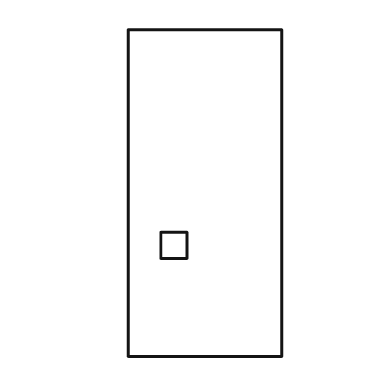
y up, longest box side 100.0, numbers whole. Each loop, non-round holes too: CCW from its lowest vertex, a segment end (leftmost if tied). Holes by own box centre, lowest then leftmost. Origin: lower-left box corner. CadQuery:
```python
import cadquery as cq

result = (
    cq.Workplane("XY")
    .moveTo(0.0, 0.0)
    .lineTo(47.0, 0.0)
    .lineTo(47.0, 100.0)
    .lineTo(0.0, 100.0)
    .close()
    .moveTo(10.0, 30.0)
    .lineTo(18.0, 30.0)
    .lineTo(18.0, 38.0)
    .lineTo(10.0, 38.0)
    .close()
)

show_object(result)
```